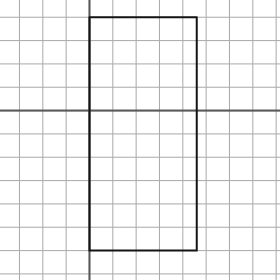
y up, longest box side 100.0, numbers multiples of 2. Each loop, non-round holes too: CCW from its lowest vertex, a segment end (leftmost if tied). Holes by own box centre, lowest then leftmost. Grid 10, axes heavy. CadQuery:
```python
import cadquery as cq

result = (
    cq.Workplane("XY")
    .moveTo(0.0, -60.0)
    .lineTo(46.0, -60.0)
    .lineTo(46.0, 40.0)
    .lineTo(0.0, 40.0)
    .close()
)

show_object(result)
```